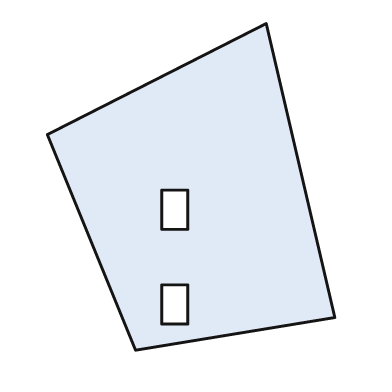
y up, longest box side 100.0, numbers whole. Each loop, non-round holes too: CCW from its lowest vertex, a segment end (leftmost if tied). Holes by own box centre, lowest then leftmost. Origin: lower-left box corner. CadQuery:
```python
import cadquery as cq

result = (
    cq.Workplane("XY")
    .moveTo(27.0, 0.0)
    .lineTo(88.0, 10.0)
    .lineTo(67.0, 100.0)
    .lineTo(0.0, 66.0)
    .close()
    .moveTo(35.0, 8.0)
    .lineTo(43.0, 8.0)
    .lineTo(43.0, 20.0)
    .lineTo(35.0, 20.0)
    .close()
    .moveTo(35.0, 37.0)
    .lineTo(43.0, 37.0)
    .lineTo(43.0, 49.0)
    .lineTo(35.0, 49.0)
    .close()
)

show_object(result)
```